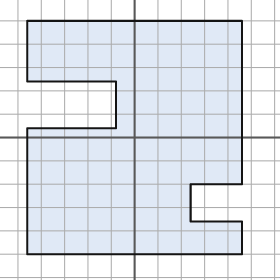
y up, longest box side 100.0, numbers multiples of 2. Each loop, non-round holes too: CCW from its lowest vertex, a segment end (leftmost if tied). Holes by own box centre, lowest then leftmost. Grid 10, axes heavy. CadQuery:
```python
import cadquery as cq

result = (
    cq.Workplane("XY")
    .moveTo(-46.0, -50.0)
    .lineTo(46.0, -50.0)
    .lineTo(46.0, -36.0)
    .lineTo(24.0, -36.0)
    .lineTo(24.0, -20.0)
    .lineTo(46.0, -20.0)
    .lineTo(46.0, 50.0)
    .lineTo(-46.0, 50.0)
    .lineTo(-46.0, 24.0)
    .lineTo(-8.0, 24.0)
    .lineTo(-8.0, 4.0)
    .lineTo(-46.0, 4.0)
    .close()
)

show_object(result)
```